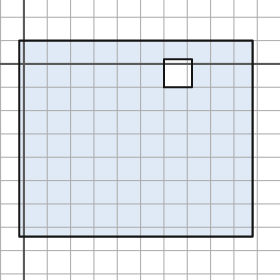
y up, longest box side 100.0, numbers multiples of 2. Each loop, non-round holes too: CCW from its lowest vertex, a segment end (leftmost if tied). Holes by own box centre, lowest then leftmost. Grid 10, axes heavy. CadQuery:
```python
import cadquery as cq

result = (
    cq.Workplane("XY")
    .moveTo(-2.0, -74.0)
    .lineTo(98.0, -74.0)
    .lineTo(98.0, 10.0)
    .lineTo(-2.0, 10.0)
    .close()
    .moveTo(60.0, -10.0)
    .lineTo(72.0, -10.0)
    .lineTo(72.0, 2.0)
    .lineTo(60.0, 2.0)
    .close()
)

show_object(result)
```